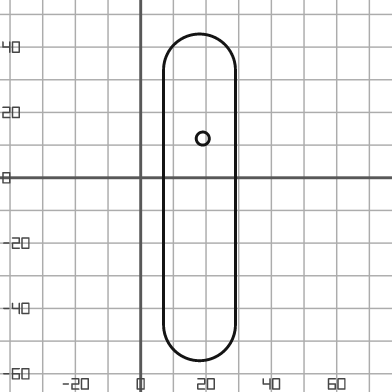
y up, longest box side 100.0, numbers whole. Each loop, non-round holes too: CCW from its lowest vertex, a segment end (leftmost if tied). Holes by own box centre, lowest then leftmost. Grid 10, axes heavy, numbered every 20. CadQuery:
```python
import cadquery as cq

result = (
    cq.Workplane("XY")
    .moveTo(7.0, -45.0)
    .threePointArc((18.0, -56.0), (29.0, -45.0))
    .lineTo(29.0, 33.0)
    .threePointArc((18.0, 44.0), (7.0, 33.0))
    .close()
    .moveTo(19.0, 12.0)
    .circle(2.0)
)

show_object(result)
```